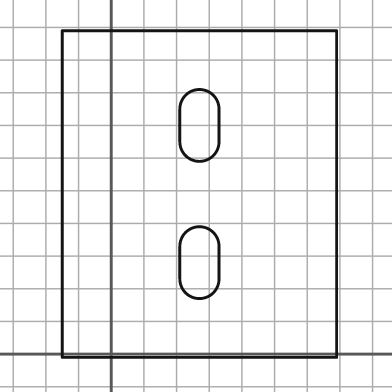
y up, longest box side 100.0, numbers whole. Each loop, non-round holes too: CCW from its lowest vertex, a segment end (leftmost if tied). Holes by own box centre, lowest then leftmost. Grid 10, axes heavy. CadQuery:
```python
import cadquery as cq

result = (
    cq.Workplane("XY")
    .moveTo(-15.0, -1.0)
    .lineTo(69.0, -1.0)
    .lineTo(69.0, 99.0)
    .lineTo(-15.0, 99.0)
    .close()
    .moveTo(21.0, 23.0)
    .threePointArc((27.0, 17.0), (33.0, 23.0))
    .lineTo(33.0, 33.0)
    .threePointArc((27.0, 39.0), (21.0, 33.0))
    .close()
    .moveTo(21.0, 65.0)
    .threePointArc((27.0, 59.0), (33.0, 65.0))
    .lineTo(33.0, 75.0)
    .threePointArc((27.0, 81.0), (21.0, 75.0))
    .close()
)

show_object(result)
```